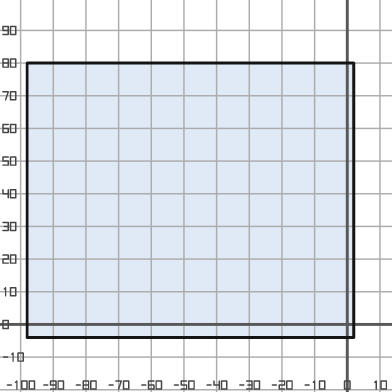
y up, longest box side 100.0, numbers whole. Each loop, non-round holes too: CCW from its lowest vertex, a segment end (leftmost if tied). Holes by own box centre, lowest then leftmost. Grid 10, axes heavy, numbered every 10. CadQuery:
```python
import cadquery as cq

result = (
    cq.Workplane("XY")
    .moveTo(-98.0, -4.0)
    .lineTo(2.0, -4.0)
    .lineTo(2.0, 80.0)
    .lineTo(-98.0, 80.0)
    .close()
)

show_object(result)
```